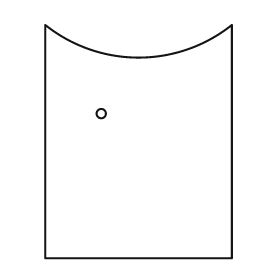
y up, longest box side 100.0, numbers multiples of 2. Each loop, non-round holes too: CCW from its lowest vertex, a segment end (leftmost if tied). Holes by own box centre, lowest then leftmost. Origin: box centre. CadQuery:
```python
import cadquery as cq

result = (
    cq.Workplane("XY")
    .moveTo(-40.0, -50.0)
    .lineTo(40.0, -50.0)
    .lineTo(40.0, 50.0)
    .threePointArc((0.0, 36.0), (-40.0, 50.0))
    .close()
    .moveTo(-16.0, 12.0)
    .circle(2.0)
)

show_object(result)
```